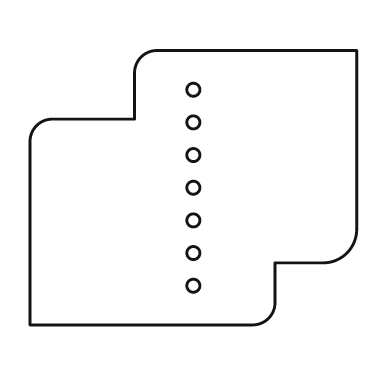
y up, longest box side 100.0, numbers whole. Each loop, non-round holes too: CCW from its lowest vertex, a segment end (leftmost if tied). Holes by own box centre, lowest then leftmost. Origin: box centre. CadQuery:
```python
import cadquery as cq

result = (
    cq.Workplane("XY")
    .moveTo(-50.0, -42.0)
    .lineTo(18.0, -42.0)
    .threePointArc((23.0, -40.0), (25.0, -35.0))
    .lineTo(25.0, -23.0)
    .lineTo(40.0, -23.0)
    .threePointArc((47.0, -20.0), (50.0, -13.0))
    .lineTo(50.0, 42.0)
    .lineTo(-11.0, 42.0)
    .threePointArc((-16.0, 40.0), (-18.0, 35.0))
    .lineTo(-18.0, 21.0)
    .lineTo(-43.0, 21.0)
    .threePointArc((-48.0, 19.0), (-50.0, 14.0))
    .close()
    .moveTo(0.0, -30.0)
    .circle(2.0)
    .moveTo(0.0, -20.0)
    .circle(2.0)
    .moveTo(0.0, -10.0)
    .circle(2.0)
    .moveTo(0.0, 0.0)
    .circle(2.0)
    .moveTo(0.0, 10.0)
    .circle(2.0)
    .moveTo(0.0, 20.0)
    .circle(2.0)
    .moveTo(0.0, 30.0)
    .circle(2.0)
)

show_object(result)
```